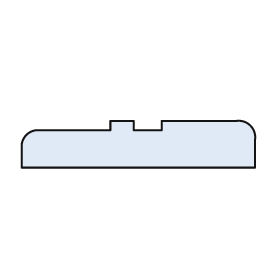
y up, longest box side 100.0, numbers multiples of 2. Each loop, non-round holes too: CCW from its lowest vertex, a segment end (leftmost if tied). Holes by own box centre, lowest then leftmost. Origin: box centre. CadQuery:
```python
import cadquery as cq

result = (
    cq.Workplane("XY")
    .moveTo(-50.0, -10.0)
    .lineTo(50.0, -10.0)
    .lineTo(50.0, 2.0)
    .threePointArc((48.0, 8.0), (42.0, 10.0))
    .lineTo(10.0, 10.0)
    .lineTo(10.0, 6.0)
    .lineTo(-2.0, 6.0)
    .lineTo(-2.0, 10.0)
    .lineTo(-12.0, 10.0)
    .lineTo(-12.0, 6.0)
    .lineTo(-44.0, 6.0)
    .threePointArc((-48.0, 4.0), (-50.0, 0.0))
    .close()
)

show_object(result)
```